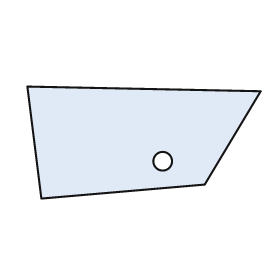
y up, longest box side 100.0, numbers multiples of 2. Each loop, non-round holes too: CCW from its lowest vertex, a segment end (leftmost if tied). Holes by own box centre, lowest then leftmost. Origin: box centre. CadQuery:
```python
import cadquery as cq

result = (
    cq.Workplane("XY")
    .moveTo(-44.0, -24.0)
    .lineTo(26.0, -18.0)
    .lineTo(50.0, 22.0)
    .lineTo(-50.0, 24.0)
    .close()
    .moveTo(8.0, -8.0)
    .circle(4.0)
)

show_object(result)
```